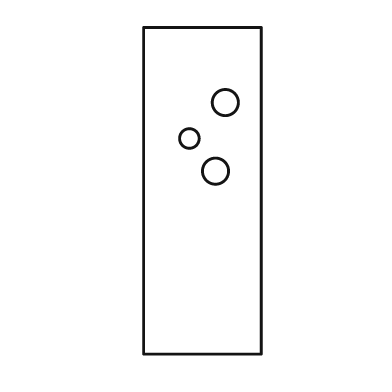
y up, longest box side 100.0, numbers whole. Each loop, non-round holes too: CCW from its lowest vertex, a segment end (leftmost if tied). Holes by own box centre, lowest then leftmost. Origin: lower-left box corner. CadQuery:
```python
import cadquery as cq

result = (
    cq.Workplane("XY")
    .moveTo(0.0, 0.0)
    .lineTo(36.0, 0.0)
    .lineTo(36.0, 100.0)
    .lineTo(0.0, 100.0)
    .close()
    .moveTo(22.0, 56.0)
    .circle(4.0)
    .moveTo(14.0, 66.0)
    .circle(3.0)
    .moveTo(25.0, 77.0)
    .circle(4.0)
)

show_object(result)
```